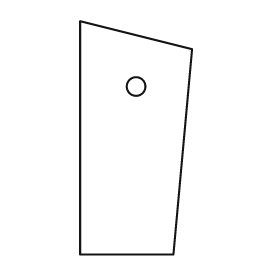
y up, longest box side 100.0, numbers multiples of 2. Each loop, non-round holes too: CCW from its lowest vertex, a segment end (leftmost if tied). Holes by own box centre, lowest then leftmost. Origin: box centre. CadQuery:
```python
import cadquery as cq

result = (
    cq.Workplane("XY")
    .moveTo(-24.0, -50.0)
    .lineTo(16.0, -50.0)
    .lineTo(24.0, 38.0)
    .lineTo(-24.0, 50.0)
    .close()
    .moveTo(0.0, 22.0)
    .circle(4.0)
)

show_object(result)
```